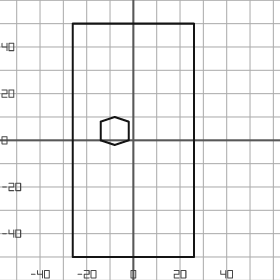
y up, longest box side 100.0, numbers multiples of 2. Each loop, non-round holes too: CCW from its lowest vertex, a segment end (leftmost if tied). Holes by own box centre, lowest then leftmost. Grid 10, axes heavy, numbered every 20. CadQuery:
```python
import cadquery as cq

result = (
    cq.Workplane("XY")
    .moveTo(-26.0, -50.0)
    .lineTo(26.0, -50.0)
    .lineTo(26.0, 50.0)
    .lineTo(-26.0, 50.0)
    .close()
    .moveTo(-8.0, -2.0)
    .lineTo(-2.0, 0.0)
    .lineTo(-2.0, 8.0)
    .lineTo(-8.0, 10.0)
    .lineTo(-14.0, 8.0)
    .lineTo(-14.0, 0.0)
    .close()
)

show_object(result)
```